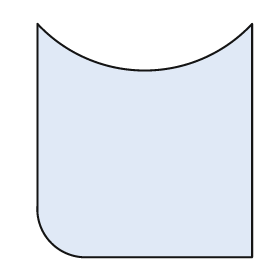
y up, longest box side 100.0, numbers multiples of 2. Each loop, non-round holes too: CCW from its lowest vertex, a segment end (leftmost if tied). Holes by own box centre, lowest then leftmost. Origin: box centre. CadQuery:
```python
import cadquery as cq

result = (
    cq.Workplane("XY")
    .moveTo(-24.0, -50.0)
    .lineTo(46.0, -50.0)
    .lineTo(46.0, 50.0)
    .threePointArc((0.0, 30.0), (-46.0, 50.0))
    .lineTo(-46.0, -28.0)
    .threePointArc((-40.0, -44.0), (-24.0, -50.0))
    .close()
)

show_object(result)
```